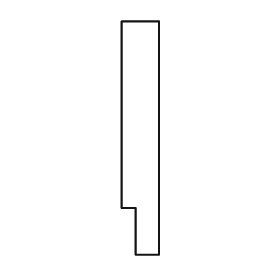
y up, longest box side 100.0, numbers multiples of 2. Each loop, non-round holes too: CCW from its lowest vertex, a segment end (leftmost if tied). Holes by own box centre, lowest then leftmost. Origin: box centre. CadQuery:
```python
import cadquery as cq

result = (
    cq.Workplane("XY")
    .moveTo(-2.0, -50.0)
    .lineTo(8.0, -50.0)
    .lineTo(8.0, 50.0)
    .lineTo(-8.0, 50.0)
    .lineTo(-8.0, -30.0)
    .lineTo(-2.0, -30.0)
    .close()
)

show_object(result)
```